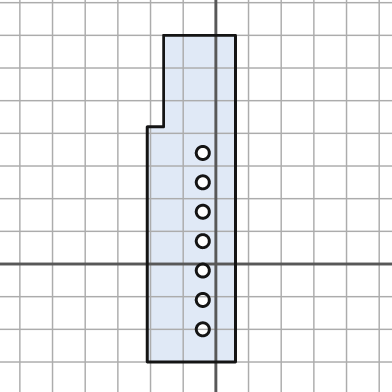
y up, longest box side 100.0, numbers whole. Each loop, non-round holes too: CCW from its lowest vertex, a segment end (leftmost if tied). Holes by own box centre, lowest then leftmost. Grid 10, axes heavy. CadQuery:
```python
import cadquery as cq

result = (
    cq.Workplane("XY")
    .moveTo(-21.0, -30.0)
    .lineTo(6.0, -30.0)
    .lineTo(6.0, 70.0)
    .lineTo(-16.0, 70.0)
    .lineTo(-16.0, 42.0)
    .lineTo(-21.0, 42.0)
    .close()
    .moveTo(-4.0, -20.0)
    .circle(2.0)
    .moveTo(-4.0, -11.0)
    .circle(2.0)
    .moveTo(-4.0, -2.0)
    .circle(2.0)
    .moveTo(-4.0, 7.0)
    .circle(2.0)
    .moveTo(-4.0, 16.0)
    .circle(2.0)
    .moveTo(-4.0, 25.0)
    .circle(2.0)
    .moveTo(-4.0, 34.0)
    .circle(2.0)
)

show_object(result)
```